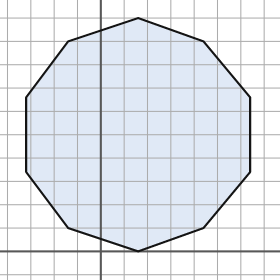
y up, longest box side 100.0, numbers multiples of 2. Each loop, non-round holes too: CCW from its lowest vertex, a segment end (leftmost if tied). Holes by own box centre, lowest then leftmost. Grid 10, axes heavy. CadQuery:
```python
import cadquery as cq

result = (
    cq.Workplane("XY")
    .moveTo(16.0, 0.0)
    .lineTo(44.0, 10.0)
    .lineTo(64.0, 34.0)
    .lineTo(64.0, 66.0)
    .lineTo(44.0, 90.0)
    .lineTo(16.0, 100.0)
    .lineTo(-14.0, 90.0)
    .lineTo(-32.0, 66.0)
    .lineTo(-32.0, 34.0)
    .lineTo(-14.0, 10.0)
    .close()
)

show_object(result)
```